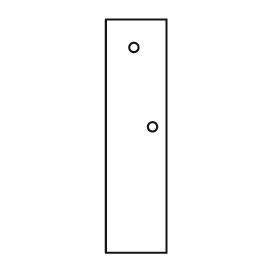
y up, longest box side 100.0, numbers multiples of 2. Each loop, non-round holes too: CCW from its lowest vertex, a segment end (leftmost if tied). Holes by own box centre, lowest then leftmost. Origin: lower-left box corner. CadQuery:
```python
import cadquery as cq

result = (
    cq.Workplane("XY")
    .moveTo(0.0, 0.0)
    .lineTo(26.0, 0.0)
    .lineTo(26.0, 100.0)
    .lineTo(0.0, 100.0)
    .close()
    .moveTo(20.0, 54.0)
    .circle(2.0)
    .moveTo(12.0, 88.0)
    .circle(2.0)
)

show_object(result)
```